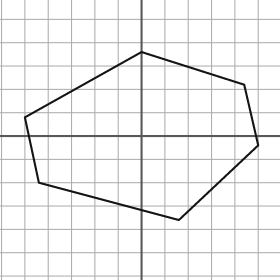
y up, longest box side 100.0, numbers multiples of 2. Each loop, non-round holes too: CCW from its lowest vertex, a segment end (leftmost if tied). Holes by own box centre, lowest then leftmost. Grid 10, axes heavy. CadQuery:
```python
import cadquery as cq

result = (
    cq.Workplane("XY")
    .moveTo(16.0, -36.0)
    .lineTo(50.0, -4.0)
    .lineTo(44.0, 22.0)
    .lineTo(0.0, 36.0)
    .lineTo(-50.0, 8.0)
    .lineTo(-44.0, -20.0)
    .close()
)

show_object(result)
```